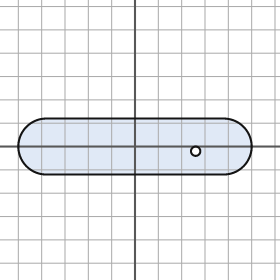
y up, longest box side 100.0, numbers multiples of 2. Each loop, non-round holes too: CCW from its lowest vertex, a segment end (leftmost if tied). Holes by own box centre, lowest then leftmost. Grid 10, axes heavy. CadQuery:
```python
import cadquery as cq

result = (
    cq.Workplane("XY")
    .moveTo(-38.0, -12.0)
    .lineTo(38.0, -12.0)
    .threePointArc((50.0, 0.0), (38.0, 12.0))
    .lineTo(-38.0, 12.0)
    .threePointArc((-50.0, 0.0), (-38.0, -12.0))
    .close()
    .moveTo(26.0, -2.0)
    .circle(2.0)
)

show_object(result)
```